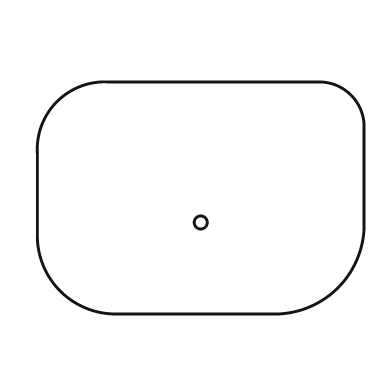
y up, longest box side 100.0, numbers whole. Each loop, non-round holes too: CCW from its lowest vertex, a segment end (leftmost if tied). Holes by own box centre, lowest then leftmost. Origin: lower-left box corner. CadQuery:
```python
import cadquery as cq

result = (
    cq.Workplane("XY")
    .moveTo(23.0, 0.0)
    .lineTo(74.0, 0.0)
    .threePointArc((92.0, 8.0), (100.0, 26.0))
    .lineTo(100.0, 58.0)
    .threePointArc((96.0, 67.0), (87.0, 71.0))
    .lineTo(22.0, 71.0)
    .threePointArc((6.0, 65.0), (0.0, 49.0))
    .lineTo(0.0, 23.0)
    .threePointArc((7.0, 7.0), (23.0, 0.0))
    .close()
    .moveTo(50.0, 28.0)
    .circle(2.0)
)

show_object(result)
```